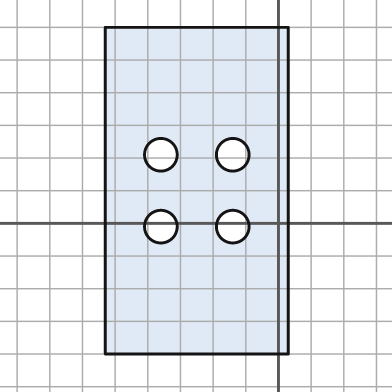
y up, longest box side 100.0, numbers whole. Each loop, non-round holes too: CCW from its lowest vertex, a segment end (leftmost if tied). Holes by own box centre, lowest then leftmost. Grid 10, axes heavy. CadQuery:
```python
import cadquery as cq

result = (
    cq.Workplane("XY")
    .moveTo(-53.0, -40.0)
    .lineTo(3.0, -40.0)
    .lineTo(3.0, 60.0)
    .lineTo(-53.0, 60.0)
    .close()
    .moveTo(-36.0, -1.0)
    .circle(5.0)
    .moveTo(-14.0, -1.0)
    .circle(5.0)
    .moveTo(-36.0, 21.0)
    .circle(5.0)
    .moveTo(-14.0, 21.0)
    .circle(5.0)
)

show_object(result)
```